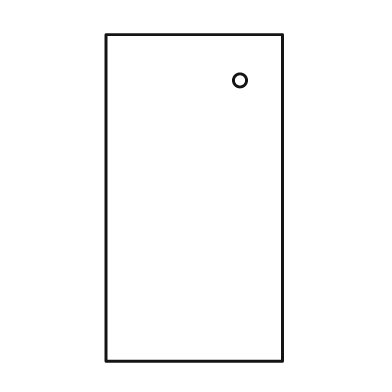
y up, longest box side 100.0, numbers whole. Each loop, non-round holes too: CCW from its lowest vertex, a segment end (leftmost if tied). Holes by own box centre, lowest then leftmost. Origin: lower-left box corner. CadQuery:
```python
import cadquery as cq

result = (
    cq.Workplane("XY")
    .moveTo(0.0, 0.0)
    .lineTo(54.0, 0.0)
    .lineTo(54.0, 100.0)
    .lineTo(0.0, 100.0)
    .close()
    .moveTo(41.0, 86.0)
    .circle(2.0)
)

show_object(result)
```